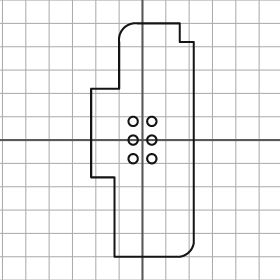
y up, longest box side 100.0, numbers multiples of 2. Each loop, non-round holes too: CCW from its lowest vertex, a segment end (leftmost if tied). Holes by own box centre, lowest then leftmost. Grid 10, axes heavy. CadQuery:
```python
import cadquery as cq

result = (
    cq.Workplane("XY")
    .moveTo(-12.0, -50.0)
    .lineTo(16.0, -50.0)
    .threePointArc((20.0, -48.0), (22.0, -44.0))
    .lineTo(22.0, 42.0)
    .lineTo(16.0, 42.0)
    .lineTo(16.0, 50.0)
    .lineTo(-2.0, 50.0)
    .threePointArc((-8.0, 48.0), (-10.0, 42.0))
    .lineTo(-10.0, 22.0)
    .lineTo(-22.0, 22.0)
    .lineTo(-22.0, -16.0)
    .lineTo(-12.0, -16.0)
    .close()
    .moveTo(-4.0, -8.0)
    .circle(2.0)
    .moveTo(4.0, -8.0)
    .circle(2.0)
    .moveTo(-4.0, 0.0)
    .circle(2.0)
    .moveTo(4.0, 0.0)
    .circle(2.0)
    .moveTo(-4.0, 8.0)
    .circle(2.0)
    .moveTo(4.0, 8.0)
    .circle(2.0)
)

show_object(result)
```